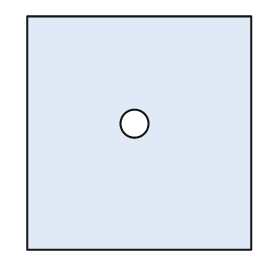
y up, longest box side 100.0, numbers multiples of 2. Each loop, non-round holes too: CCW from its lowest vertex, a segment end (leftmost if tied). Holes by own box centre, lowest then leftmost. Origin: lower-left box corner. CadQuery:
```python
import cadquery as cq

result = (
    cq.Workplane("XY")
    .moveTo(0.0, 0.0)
    .lineTo(96.0, 0.0)
    .lineTo(96.0, 100.0)
    .lineTo(0.0, 100.0)
    .close()
    .moveTo(46.0, 54.0)
    .circle(6.0)
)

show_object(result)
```